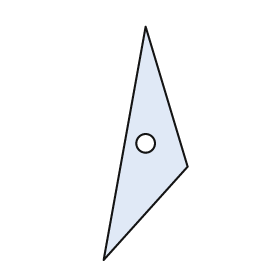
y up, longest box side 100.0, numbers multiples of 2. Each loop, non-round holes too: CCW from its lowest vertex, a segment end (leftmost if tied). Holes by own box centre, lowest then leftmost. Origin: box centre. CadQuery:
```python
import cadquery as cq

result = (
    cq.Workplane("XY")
    .moveTo(-18.0, -50.0)
    .lineTo(18.0, -10.0)
    .lineTo(0.0, 50.0)
    .close()
    .moveTo(0.0, 0.0)
    .circle(4.0)
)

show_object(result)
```